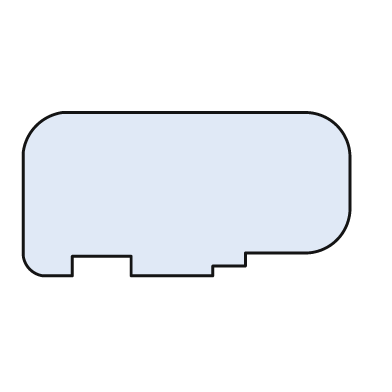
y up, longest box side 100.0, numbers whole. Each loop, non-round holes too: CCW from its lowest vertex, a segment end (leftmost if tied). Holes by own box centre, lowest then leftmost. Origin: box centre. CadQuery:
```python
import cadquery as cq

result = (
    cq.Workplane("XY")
    .moveTo(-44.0, -25.0)
    .lineTo(-35.0, -25.0)
    .lineTo(-35.0, -19.0)
    .lineTo(-17.0, -19.0)
    .lineTo(-17.0, -25.0)
    .lineTo(8.0, -25.0)
    .lineTo(8.0, -22.0)
    .lineTo(18.0, -22.0)
    .lineTo(18.0, -18.0)
    .lineTo(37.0, -18.0)
    .threePointArc((46.0, -14.0), (50.0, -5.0))
    .lineTo(50.0, 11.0)
    .threePointArc((46.0, 21.0), (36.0, 25.0))
    .lineTo(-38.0, 25.0)
    .threePointArc((-46.0, 21.0), (-50.0, 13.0))
    .lineTo(-50.0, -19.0)
    .threePointArc((-48.0, -23.0), (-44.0, -25.0))
    .close()
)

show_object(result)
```